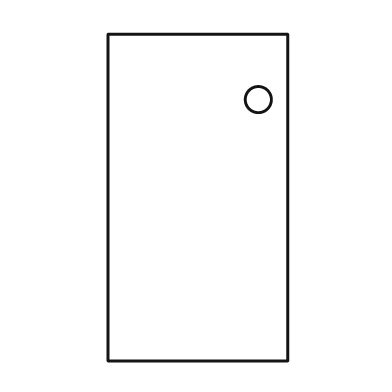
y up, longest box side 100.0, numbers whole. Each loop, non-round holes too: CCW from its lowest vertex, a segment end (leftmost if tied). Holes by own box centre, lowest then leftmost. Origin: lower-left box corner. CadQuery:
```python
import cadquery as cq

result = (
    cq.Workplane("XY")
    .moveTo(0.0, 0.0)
    .lineTo(55.0, 0.0)
    .lineTo(55.0, 100.0)
    .lineTo(0.0, 100.0)
    .close()
    .moveTo(46.0, 80.0)
    .circle(4.0)
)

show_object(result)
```